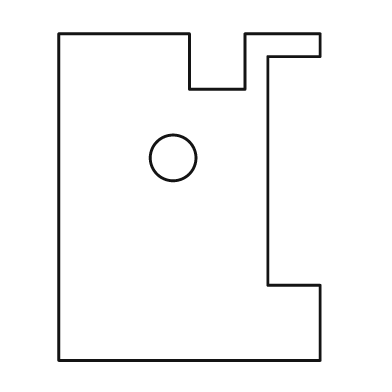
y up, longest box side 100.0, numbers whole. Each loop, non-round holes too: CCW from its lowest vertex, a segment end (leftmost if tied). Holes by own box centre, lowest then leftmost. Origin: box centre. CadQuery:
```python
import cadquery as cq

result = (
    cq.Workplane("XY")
    .moveTo(-40.0, -50.0)
    .lineTo(40.0, -50.0)
    .lineTo(40.0, -27.0)
    .lineTo(24.0, -27.0)
    .lineTo(24.0, 43.0)
    .lineTo(40.0, 43.0)
    .lineTo(40.0, 50.0)
    .lineTo(17.0, 50.0)
    .lineTo(17.0, 33.0)
    .lineTo(0.0, 33.0)
    .lineTo(0.0, 50.0)
    .lineTo(-40.0, 50.0)
    .close()
    .moveTo(-5.0, 12.0)
    .circle(7.0)
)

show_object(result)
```